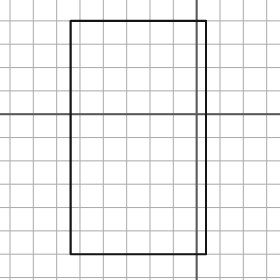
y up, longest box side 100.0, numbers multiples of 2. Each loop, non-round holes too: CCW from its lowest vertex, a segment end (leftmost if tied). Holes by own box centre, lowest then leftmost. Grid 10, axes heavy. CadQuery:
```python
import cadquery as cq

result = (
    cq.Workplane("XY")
    .moveTo(-54.0, -60.0)
    .lineTo(4.0, -60.0)
    .lineTo(4.0, 40.0)
    .lineTo(-54.0, 40.0)
    .close()
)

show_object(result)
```